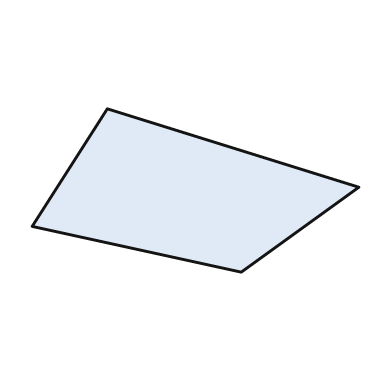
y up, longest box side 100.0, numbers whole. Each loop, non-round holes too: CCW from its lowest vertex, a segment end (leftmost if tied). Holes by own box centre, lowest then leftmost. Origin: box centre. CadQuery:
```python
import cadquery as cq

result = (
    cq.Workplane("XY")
    .moveTo(14.0, -25.0)
    .lineTo(50.0, 1.0)
    .lineTo(-27.0, 25.0)
    .lineTo(-50.0, -11.0)
    .close()
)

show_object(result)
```